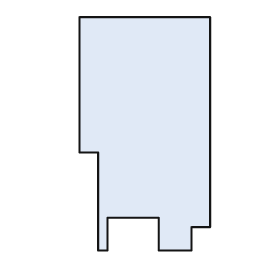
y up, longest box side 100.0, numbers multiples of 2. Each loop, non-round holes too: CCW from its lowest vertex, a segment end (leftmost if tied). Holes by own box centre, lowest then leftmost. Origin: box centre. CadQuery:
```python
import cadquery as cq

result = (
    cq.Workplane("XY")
    .moveTo(-20.0, -50.0)
    .lineTo(-16.0, -50.0)
    .lineTo(-16.0, -36.0)
    .lineTo(6.0, -36.0)
    .lineTo(6.0, -50.0)
    .lineTo(20.0, -50.0)
    .lineTo(20.0, -40.0)
    .lineTo(28.0, -40.0)
    .lineTo(28.0, 50.0)
    .lineTo(-28.0, 50.0)
    .lineTo(-28.0, -8.0)
    .lineTo(-20.0, -8.0)
    .close()
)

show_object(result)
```